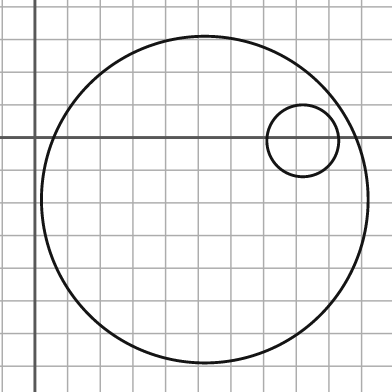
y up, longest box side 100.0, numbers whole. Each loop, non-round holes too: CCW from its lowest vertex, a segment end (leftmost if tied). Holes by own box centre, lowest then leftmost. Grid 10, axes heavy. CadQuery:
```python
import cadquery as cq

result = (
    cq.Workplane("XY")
    .moveTo(52.0, -19.0)
    .circle(50.0)
    .moveTo(82.0, -1.0)
    .circle(11.0)
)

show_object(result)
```